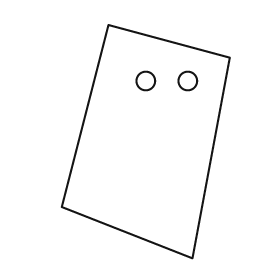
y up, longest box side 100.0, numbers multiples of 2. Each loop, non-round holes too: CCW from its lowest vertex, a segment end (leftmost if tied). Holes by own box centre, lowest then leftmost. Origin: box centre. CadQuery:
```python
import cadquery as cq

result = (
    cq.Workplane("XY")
    .moveTo(20.0, -50.0)
    .lineTo(36.0, 36.0)
    .lineTo(-16.0, 50.0)
    .lineTo(-36.0, -28.0)
    .close()
    .moveTo(0.0, 26.0)
    .circle(4.0)
    .moveTo(18.0, 26.0)
    .circle(4.0)
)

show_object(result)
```